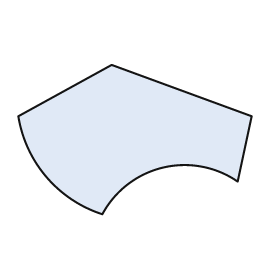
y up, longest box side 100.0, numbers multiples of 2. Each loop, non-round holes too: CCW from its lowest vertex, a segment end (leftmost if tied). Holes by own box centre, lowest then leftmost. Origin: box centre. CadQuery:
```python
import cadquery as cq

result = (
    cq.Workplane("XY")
    .moveTo(-14.0, -32.0)
    .threePointArc((12.0, -12.0), (44.0, -18.0))
    .lineTo(50.0, 10.0)
    .lineTo(-10.0, 32.0)
    .lineTo(-50.0, 10.0)
    .threePointArc((-38.0, -16.0), (-14.0, -32.0))
    .close()
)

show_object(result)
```